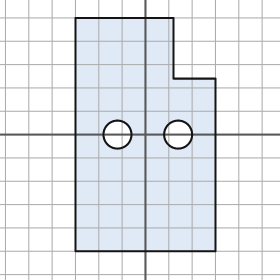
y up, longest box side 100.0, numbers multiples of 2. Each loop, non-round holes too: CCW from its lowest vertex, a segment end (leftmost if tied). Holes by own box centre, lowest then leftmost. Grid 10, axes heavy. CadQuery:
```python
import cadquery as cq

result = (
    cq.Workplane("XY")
    .moveTo(-30.0, -50.0)
    .lineTo(30.0, -50.0)
    .lineTo(30.0, 24.0)
    .lineTo(12.0, 24.0)
    .lineTo(12.0, 50.0)
    .lineTo(-30.0, 50.0)
    .close()
    .moveTo(-12.0, 0.0)
    .circle(6.0)
    .moveTo(14.0, 0.0)
    .circle(6.0)
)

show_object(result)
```